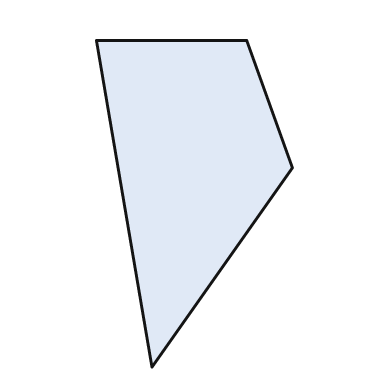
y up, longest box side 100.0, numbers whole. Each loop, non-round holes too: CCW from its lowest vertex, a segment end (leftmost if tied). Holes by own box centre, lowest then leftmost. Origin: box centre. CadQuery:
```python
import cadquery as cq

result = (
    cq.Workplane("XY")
    .moveTo(-13.0, -50.0)
    .lineTo(30.0, 11.0)
    .lineTo(16.0, 50.0)
    .lineTo(-30.0, 50.0)
    .close()
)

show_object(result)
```